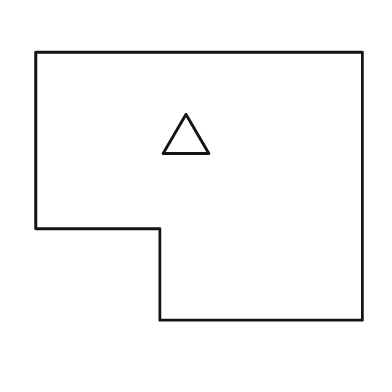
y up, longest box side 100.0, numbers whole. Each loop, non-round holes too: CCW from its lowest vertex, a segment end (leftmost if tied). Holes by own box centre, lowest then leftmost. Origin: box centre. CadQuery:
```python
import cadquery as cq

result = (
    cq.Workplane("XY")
    .moveTo(-12.0, -41.0)
    .lineTo(50.0, -41.0)
    .lineTo(50.0, 41.0)
    .lineTo(-50.0, 41.0)
    .lineTo(-50.0, -13.0)
    .lineTo(-12.0, -13.0)
    .close()
    .moveTo(-11.0, 10.0)
    .lineTo(3.0, 10.0)
    .lineTo(-4.0, 22.0)
    .close()
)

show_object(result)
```